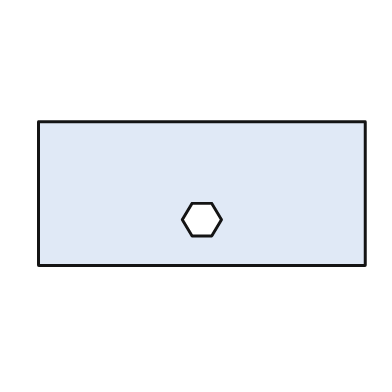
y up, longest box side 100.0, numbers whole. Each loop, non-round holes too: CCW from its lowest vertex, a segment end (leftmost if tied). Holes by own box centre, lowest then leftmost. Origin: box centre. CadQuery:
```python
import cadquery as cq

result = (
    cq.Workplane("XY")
    .moveTo(-50.0, -22.0)
    .lineTo(50.0, -22.0)
    .lineTo(50.0, 22.0)
    .lineTo(-50.0, 22.0)
    .close()
    .moveTo(-3.0, -13.0)
    .lineTo(3.0, -13.0)
    .lineTo(6.0, -8.0)
    .lineTo(3.0, -3.0)
    .lineTo(-3.0, -3.0)
    .lineTo(-6.0, -8.0)
    .close()
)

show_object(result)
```